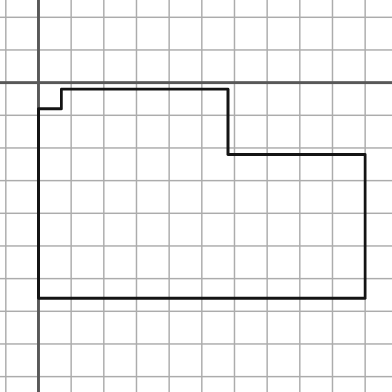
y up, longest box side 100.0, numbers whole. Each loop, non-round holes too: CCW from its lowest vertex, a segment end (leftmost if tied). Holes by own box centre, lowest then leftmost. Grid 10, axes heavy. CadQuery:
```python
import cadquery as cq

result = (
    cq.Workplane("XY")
    .moveTo(0.0, -66.0)
    .lineTo(100.0, -66.0)
    .lineTo(100.0, -22.0)
    .lineTo(58.0, -22.0)
    .lineTo(58.0, -2.0)
    .lineTo(7.0, -2.0)
    .lineTo(7.0, -8.0)
    .lineTo(0.0, -8.0)
    .close()
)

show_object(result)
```